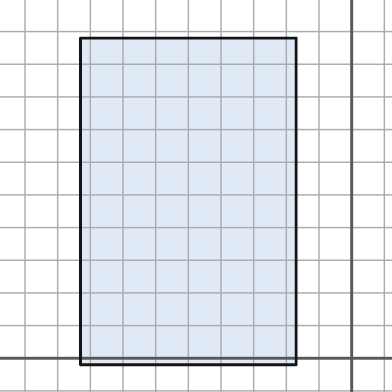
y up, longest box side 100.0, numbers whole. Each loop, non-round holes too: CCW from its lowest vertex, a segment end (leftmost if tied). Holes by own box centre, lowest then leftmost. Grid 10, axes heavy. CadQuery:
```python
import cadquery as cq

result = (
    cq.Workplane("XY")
    .moveTo(-83.0, -2.0)
    .lineTo(-17.0, -2.0)
    .lineTo(-17.0, 98.0)
    .lineTo(-83.0, 98.0)
    .close()
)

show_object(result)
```